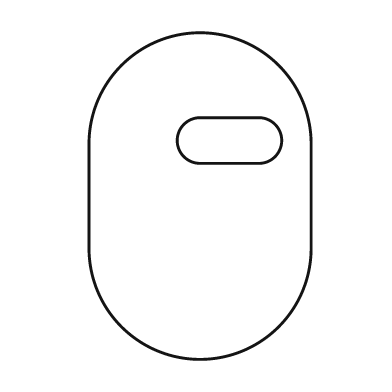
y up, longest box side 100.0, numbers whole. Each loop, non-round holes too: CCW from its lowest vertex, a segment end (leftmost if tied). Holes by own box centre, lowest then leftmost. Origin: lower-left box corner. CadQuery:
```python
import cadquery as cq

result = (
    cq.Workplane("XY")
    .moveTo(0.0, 34.0)
    .threePointArc((34.0, 0.0), (68.0, 34.0))
    .lineTo(68.0, 66.0)
    .threePointArc((34.0, 100.0), (0.0, 66.0))
    .close()
    .moveTo(34.0, 60.0)
    .lineTo(52.0, 60.0)
    .threePointArc((59.0, 67.0), (52.0, 74.0))
    .lineTo(34.0, 74.0)
    .threePointArc((27.0, 67.0), (34.0, 60.0))
    .close()
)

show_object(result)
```